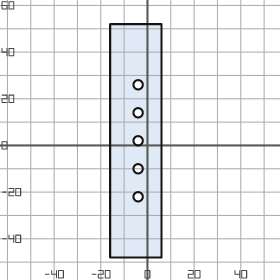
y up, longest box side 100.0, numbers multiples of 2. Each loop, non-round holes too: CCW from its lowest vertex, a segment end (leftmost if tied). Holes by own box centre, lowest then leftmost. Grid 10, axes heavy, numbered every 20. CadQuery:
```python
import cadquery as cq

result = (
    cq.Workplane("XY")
    .moveTo(-16.0, -48.0)
    .lineTo(6.0, -48.0)
    .lineTo(6.0, 52.0)
    .lineTo(-16.0, 52.0)
    .close()
    .moveTo(-4.0, -22.0)
    .circle(2.0)
    .moveTo(-4.0, -10.0)
    .circle(2.0)
    .moveTo(-4.0, 2.0)
    .circle(2.0)
    .moveTo(-4.0, 14.0)
    .circle(2.0)
    .moveTo(-4.0, 26.0)
    .circle(2.0)
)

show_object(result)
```